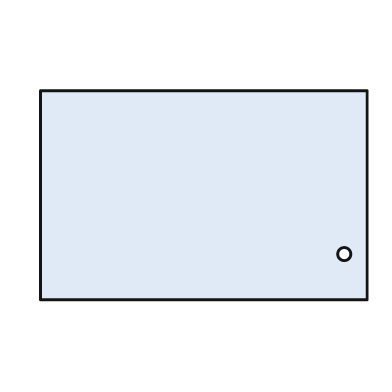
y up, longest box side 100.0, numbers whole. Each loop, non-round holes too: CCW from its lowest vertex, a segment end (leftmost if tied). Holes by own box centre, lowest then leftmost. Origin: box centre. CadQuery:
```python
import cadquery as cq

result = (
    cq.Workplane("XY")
    .moveTo(-50.0, -32.0)
    .lineTo(50.0, -32.0)
    .lineTo(50.0, 32.0)
    .lineTo(-50.0, 32.0)
    .close()
    .moveTo(43.0, -18.0)
    .circle(2.0)
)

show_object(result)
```